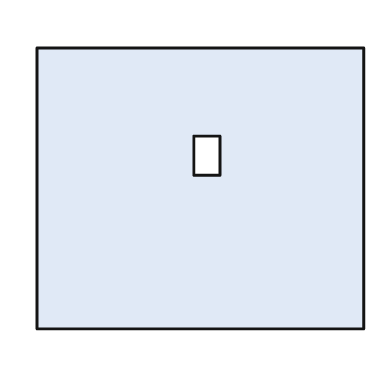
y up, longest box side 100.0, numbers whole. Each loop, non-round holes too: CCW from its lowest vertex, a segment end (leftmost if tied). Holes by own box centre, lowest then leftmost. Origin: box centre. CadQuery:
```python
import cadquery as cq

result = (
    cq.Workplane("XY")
    .moveTo(-50.0, -43.0)
    .lineTo(50.0, -43.0)
    .lineTo(50.0, 43.0)
    .lineTo(-50.0, 43.0)
    .close()
    .moveTo(-2.0, 4.0)
    .lineTo(6.0, 4.0)
    .lineTo(6.0, 16.0)
    .lineTo(-2.0, 16.0)
    .close()
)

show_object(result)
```